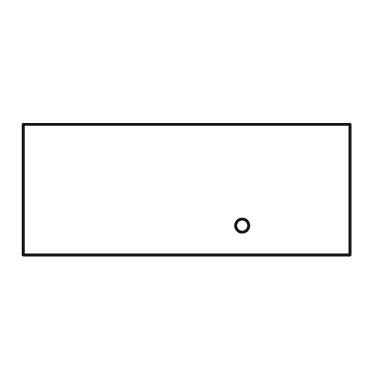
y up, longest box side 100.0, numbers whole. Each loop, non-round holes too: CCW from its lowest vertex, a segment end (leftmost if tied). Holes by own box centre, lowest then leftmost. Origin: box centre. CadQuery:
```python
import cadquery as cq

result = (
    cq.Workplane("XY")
    .moveTo(-50.0, -20.0)
    .lineTo(50.0, -20.0)
    .lineTo(50.0, 20.0)
    .lineTo(-50.0, 20.0)
    .close()
    .moveTo(17.0, -11.0)
    .circle(2.0)
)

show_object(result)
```